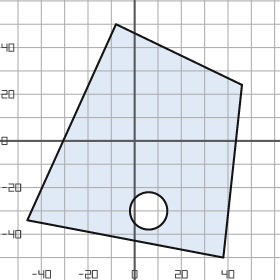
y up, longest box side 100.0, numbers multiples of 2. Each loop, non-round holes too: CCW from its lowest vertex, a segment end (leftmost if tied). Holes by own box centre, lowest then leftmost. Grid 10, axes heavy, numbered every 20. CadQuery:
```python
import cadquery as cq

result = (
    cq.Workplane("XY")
    .moveTo(38.0, -50.0)
    .lineTo(46.0, 24.0)
    .lineTo(-8.0, 50.0)
    .lineTo(-46.0, -34.0)
    .close()
    .moveTo(6.0, -30.0)
    .circle(8.0)
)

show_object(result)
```